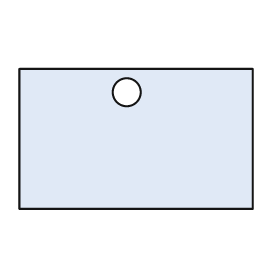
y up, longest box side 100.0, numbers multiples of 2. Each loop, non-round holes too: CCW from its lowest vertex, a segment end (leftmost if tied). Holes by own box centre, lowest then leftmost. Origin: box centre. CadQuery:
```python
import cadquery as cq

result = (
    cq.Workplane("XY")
    .moveTo(-50.0, -30.0)
    .lineTo(50.0, -30.0)
    .lineTo(50.0, 30.0)
    .lineTo(-50.0, 30.0)
    .close()
    .moveTo(-4.0, 20.0)
    .circle(6.0)
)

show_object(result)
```